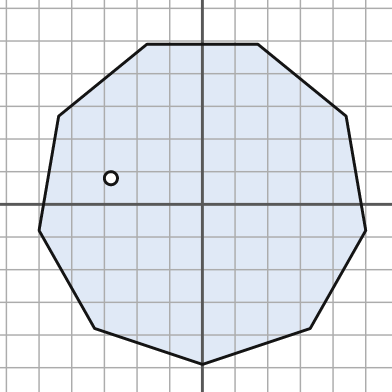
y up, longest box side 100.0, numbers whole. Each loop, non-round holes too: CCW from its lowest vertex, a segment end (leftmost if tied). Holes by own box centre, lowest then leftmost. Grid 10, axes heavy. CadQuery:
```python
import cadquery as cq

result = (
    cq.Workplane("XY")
    .moveTo(0.0, -49.0)
    .lineTo(33.0, -38.0)
    .lineTo(50.0, -8.0)
    .lineTo(44.0, 27.0)
    .lineTo(17.0, 49.0)
    .lineTo(-17.0, 49.0)
    .lineTo(-44.0, 27.0)
    .lineTo(-50.0, -8.0)
    .lineTo(-33.0, -38.0)
    .close()
    .moveTo(-28.0, 8.0)
    .circle(2.0)
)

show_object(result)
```